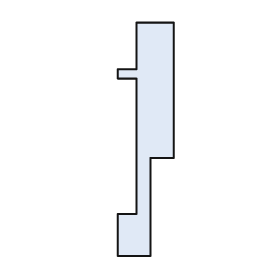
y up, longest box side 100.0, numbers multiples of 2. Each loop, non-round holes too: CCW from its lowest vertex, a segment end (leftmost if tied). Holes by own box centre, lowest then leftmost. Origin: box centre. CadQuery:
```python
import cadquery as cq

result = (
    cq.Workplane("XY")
    .moveTo(-12.0, -50.0)
    .lineTo(2.0, -50.0)
    .lineTo(2.0, -8.0)
    .lineTo(12.0, -8.0)
    .lineTo(12.0, 50.0)
    .lineTo(-4.0, 50.0)
    .lineTo(-4.0, 30.0)
    .lineTo(-12.0, 30.0)
    .lineTo(-12.0, 26.0)
    .lineTo(-4.0, 26.0)
    .lineTo(-4.0, -32.0)
    .lineTo(-12.0, -32.0)
    .close()
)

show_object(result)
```